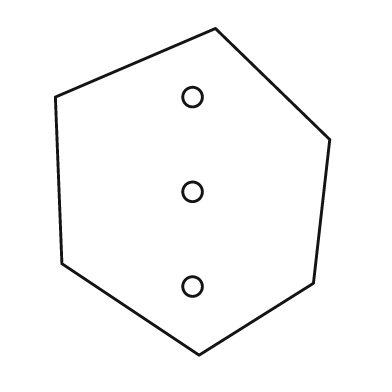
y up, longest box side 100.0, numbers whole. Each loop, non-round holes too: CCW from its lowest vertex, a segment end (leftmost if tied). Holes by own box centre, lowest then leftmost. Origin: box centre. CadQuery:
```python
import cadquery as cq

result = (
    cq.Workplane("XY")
    .moveTo(2.0, -50.0)
    .lineTo(37.0, -28.0)
    .lineTo(42.0, 16.0)
    .lineTo(7.0, 50.0)
    .lineTo(-42.0, 29.0)
    .lineTo(-40.0, -22.0)
    .close()
    .moveTo(0.0, -29.0)
    .circle(3.0)
    .moveTo(0.0, 0.0)
    .circle(3.0)
    .moveTo(0.0, 29.0)
    .circle(3.0)
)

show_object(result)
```